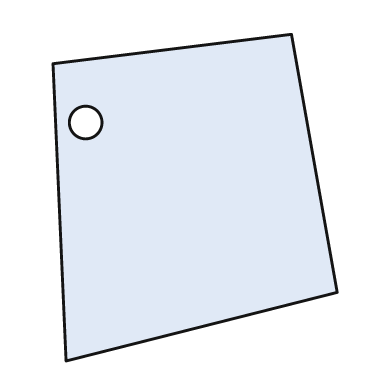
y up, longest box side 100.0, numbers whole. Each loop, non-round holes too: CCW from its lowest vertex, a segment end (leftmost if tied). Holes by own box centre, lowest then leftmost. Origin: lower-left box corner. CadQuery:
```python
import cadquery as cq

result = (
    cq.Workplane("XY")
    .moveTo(4.0, 0.0)
    .lineTo(87.0, 21.0)
    .lineTo(73.0, 100.0)
    .lineTo(0.0, 91.0)
    .close()
    .moveTo(10.0, 73.0)
    .circle(5.0)
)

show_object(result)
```